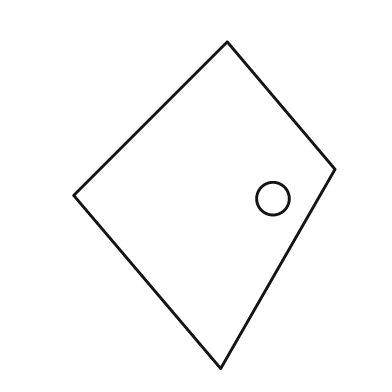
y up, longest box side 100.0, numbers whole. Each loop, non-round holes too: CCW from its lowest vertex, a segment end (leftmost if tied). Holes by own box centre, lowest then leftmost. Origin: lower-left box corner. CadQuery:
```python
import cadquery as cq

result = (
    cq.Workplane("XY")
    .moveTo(45.0, 0.0)
    .lineTo(80.0, 61.0)
    .lineTo(47.0, 100.0)
    .lineTo(0.0, 53.0)
    .close()
    .moveTo(61.0, 52.0)
    .circle(5.0)
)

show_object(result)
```